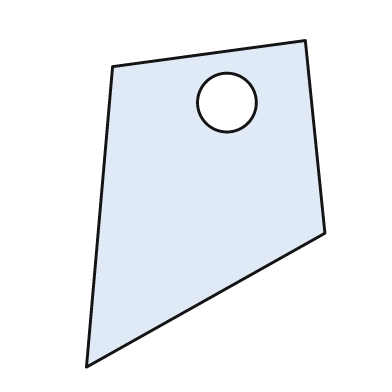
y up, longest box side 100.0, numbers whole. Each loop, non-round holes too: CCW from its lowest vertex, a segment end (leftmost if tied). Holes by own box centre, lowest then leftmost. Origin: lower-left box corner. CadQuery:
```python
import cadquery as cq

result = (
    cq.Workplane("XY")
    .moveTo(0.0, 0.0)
    .lineTo(73.0, 41.0)
    .lineTo(67.0, 100.0)
    .lineTo(8.0, 92.0)
    .close()
    .moveTo(43.0, 81.0)
    .circle(9.0)
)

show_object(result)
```